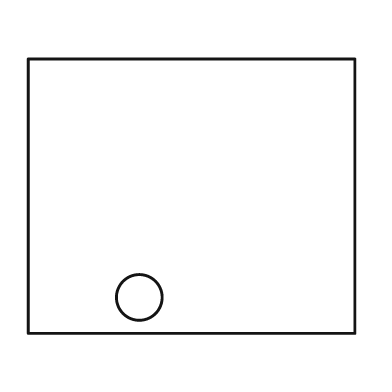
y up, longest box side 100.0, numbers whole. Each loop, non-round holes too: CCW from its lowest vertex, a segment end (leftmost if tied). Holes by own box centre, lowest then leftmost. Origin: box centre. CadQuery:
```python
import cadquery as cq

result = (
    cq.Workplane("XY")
    .moveTo(-50.0, -42.0)
    .lineTo(50.0, -42.0)
    .lineTo(50.0, 42.0)
    .lineTo(-50.0, 42.0)
    .close()
    .moveTo(-16.0, -31.0)
    .circle(7.0)
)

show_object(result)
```